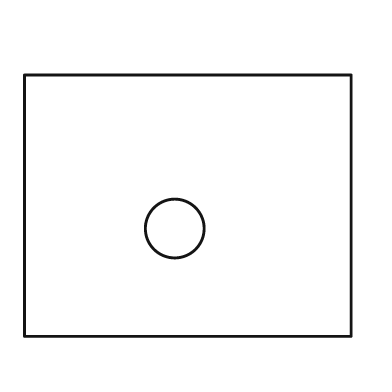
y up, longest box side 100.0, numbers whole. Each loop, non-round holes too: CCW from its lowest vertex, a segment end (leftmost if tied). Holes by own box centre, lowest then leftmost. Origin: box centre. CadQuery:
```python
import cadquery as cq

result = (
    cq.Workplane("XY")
    .moveTo(-50.0, -40.0)
    .lineTo(50.0, -40.0)
    .lineTo(50.0, 40.0)
    .lineTo(-50.0, 40.0)
    .close()
    .moveTo(-4.0, -7.0)
    .circle(9.0)
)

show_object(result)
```